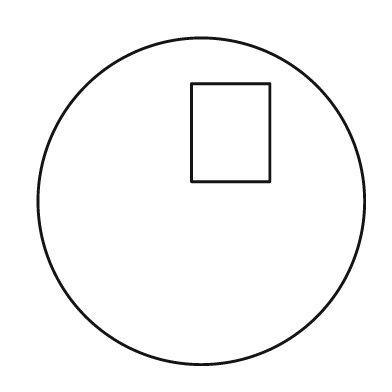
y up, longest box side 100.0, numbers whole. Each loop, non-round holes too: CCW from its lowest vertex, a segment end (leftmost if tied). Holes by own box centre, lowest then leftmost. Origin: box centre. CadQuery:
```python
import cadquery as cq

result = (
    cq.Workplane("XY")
    .moveTo(0.0, 0.0)
    .circle(50.0)
    .moveTo(-3.0, 6.0)
    .lineTo(21.0, 6.0)
    .lineTo(21.0, 36.0)
    .lineTo(-3.0, 36.0)
    .close()
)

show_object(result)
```